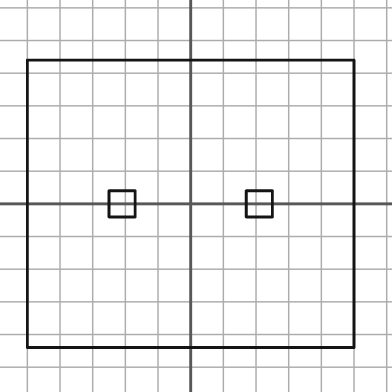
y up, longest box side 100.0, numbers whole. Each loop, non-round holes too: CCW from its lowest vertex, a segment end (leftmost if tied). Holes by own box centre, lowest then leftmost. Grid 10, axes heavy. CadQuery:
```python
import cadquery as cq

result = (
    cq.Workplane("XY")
    .moveTo(-50.0, -44.0)
    .lineTo(50.0, -44.0)
    .lineTo(50.0, 44.0)
    .lineTo(-50.0, 44.0)
    .close()
    .moveTo(-25.0, -4.0)
    .lineTo(-17.0, -4.0)
    .lineTo(-17.0, 4.0)
    .lineTo(-25.0, 4.0)
    .close()
    .moveTo(17.0, -4.0)
    .lineTo(25.0, -4.0)
    .lineTo(25.0, 4.0)
    .lineTo(17.0, 4.0)
    .close()
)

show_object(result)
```